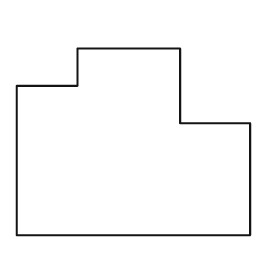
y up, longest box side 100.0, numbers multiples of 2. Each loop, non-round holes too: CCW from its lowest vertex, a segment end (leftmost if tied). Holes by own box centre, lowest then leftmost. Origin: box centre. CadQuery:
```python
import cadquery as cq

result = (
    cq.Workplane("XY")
    .moveTo(-50.0, -40.0)
    .lineTo(50.0, -40.0)
    .lineTo(50.0, 8.0)
    .lineTo(20.0, 8.0)
    .lineTo(20.0, 40.0)
    .lineTo(-24.0, 40.0)
    .lineTo(-24.0, 24.0)
    .lineTo(-50.0, 24.0)
    .close()
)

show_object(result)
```